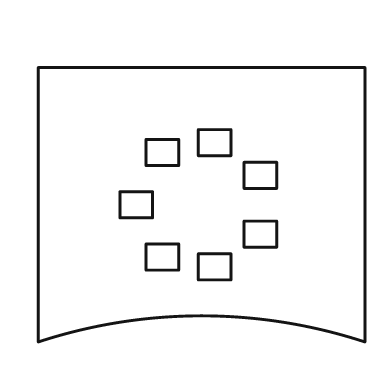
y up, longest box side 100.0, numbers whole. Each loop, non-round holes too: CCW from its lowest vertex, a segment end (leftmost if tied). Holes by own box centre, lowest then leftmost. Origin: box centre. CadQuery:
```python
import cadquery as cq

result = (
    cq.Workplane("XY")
    .moveTo(-50.0, -42.0)
    .threePointArc((0.0, -34.0), (50.0, -42.0))
    .lineTo(50.0, 42.0)
    .lineTo(-50.0, 42.0)
    .close()
    .moveTo(-1.0, -23.0)
    .lineTo(9.0, -23.0)
    .lineTo(9.0, -15.0)
    .lineTo(-1.0, -15.0)
    .close()
    .moveTo(-17.0, -20.0)
    .lineTo(-7.0, -20.0)
    .lineTo(-7.0, -12.0)
    .lineTo(-17.0, -12.0)
    .close()
    .moveTo(13.0, -13.0)
    .lineTo(23.0, -13.0)
    .lineTo(23.0, -5.0)
    .lineTo(13.0, -5.0)
    .close()
    .moveTo(-25.0, -4.0)
    .lineTo(-15.0, -4.0)
    .lineTo(-15.0, 4.0)
    .lineTo(-25.0, 4.0)
    .close()
    .moveTo(13.0, 5.0)
    .lineTo(23.0, 5.0)
    .lineTo(23.0, 13.0)
    .lineTo(13.0, 13.0)
    .close()
    .moveTo(-17.0, 12.0)
    .lineTo(-7.0, 12.0)
    .lineTo(-7.0, 20.0)
    .lineTo(-17.0, 20.0)
    .close()
    .moveTo(-1.0, 15.0)
    .lineTo(9.0, 15.0)
    .lineTo(9.0, 23.0)
    .lineTo(-1.0, 23.0)
    .close()
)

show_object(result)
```